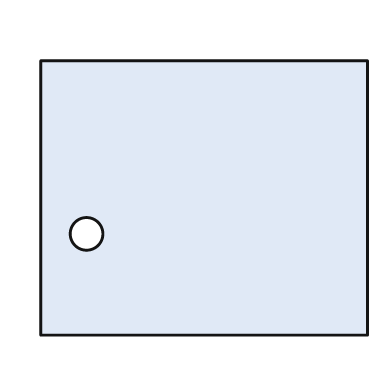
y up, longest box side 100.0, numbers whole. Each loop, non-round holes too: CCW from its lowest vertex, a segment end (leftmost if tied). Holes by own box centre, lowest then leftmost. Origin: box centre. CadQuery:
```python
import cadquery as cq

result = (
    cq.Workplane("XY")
    .moveTo(-50.0, -42.0)
    .lineTo(50.0, -42.0)
    .lineTo(50.0, 42.0)
    .lineTo(-50.0, 42.0)
    .close()
    .moveTo(-36.0, -11.0)
    .circle(5.0)
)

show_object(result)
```